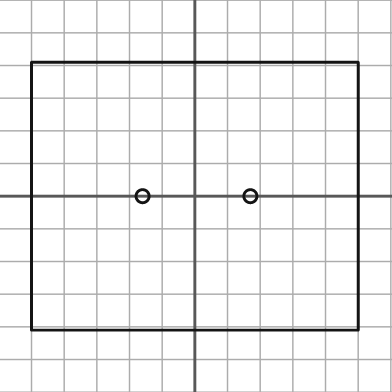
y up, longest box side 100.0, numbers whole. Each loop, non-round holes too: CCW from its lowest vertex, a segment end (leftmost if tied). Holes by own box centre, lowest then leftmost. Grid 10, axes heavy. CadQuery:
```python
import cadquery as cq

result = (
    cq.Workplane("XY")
    .moveTo(-50.0, -41.0)
    .lineTo(50.0, -41.0)
    .lineTo(50.0, 41.0)
    .lineTo(-50.0, 41.0)
    .close()
    .moveTo(-16.0, 0.0)
    .circle(2.0)
    .moveTo(17.0, 0.0)
    .circle(2.0)
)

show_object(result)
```